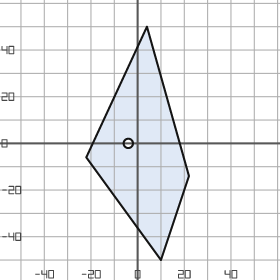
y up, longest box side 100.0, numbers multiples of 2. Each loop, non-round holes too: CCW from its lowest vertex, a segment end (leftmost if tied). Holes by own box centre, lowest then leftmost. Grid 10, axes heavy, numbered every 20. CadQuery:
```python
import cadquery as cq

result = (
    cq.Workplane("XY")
    .moveTo(10.0, -50.0)
    .lineTo(22.0, -14.0)
    .lineTo(4.0, 50.0)
    .lineTo(-22.0, -6.0)
    .close()
    .moveTo(-4.0, 0.0)
    .circle(2.0)
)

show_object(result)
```